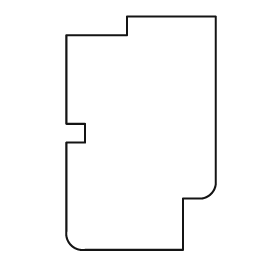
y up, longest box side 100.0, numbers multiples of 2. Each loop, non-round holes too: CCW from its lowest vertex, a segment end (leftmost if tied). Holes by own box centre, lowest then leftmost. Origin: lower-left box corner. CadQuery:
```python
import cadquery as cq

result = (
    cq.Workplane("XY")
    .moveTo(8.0, 0.0)
    .lineTo(50.0, 0.0)
    .lineTo(50.0, 22.0)
    .lineTo(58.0, 22.0)
    .threePointArc((62.0, 24.0), (64.0, 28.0))
    .lineTo(64.0, 100.0)
    .lineTo(26.0, 100.0)
    .lineTo(26.0, 92.0)
    .lineTo(0.0, 92.0)
    .lineTo(0.0, 54.0)
    .lineTo(8.0, 54.0)
    .lineTo(8.0, 46.0)
    .lineTo(0.0, 46.0)
    .lineTo(0.0, 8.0)
    .threePointArc((2.0, 2.0), (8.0, 0.0))
    .close()
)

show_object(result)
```